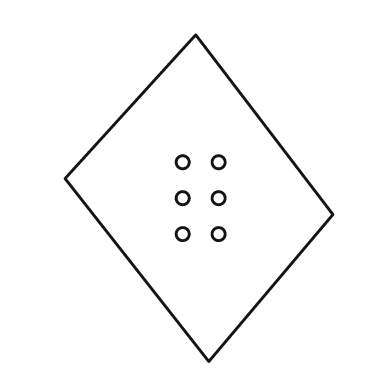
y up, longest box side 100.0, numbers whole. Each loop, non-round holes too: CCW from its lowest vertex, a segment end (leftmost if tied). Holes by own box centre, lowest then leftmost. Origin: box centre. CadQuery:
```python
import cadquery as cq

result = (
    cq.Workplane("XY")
    .moveTo(3.0, -50.0)
    .lineTo(41.0, -5.0)
    .lineTo(-1.0, 50.0)
    .lineTo(-41.0, 6.0)
    .close()
    .moveTo(-5.0, -11.0)
    .circle(2.0)
    .moveTo(6.0, -11.0)
    .circle(2.0)
    .moveTo(-5.0, 0.0)
    .circle(2.0)
    .moveTo(6.0, 0.0)
    .circle(2.0)
    .moveTo(-5.0, 11.0)
    .circle(2.0)
    .moveTo(6.0, 11.0)
    .circle(2.0)
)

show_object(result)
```